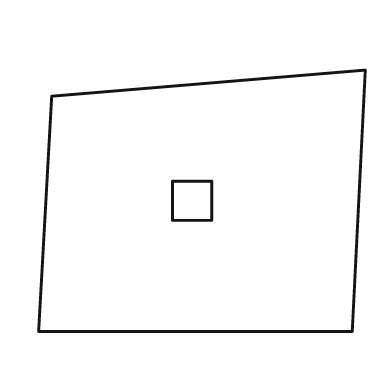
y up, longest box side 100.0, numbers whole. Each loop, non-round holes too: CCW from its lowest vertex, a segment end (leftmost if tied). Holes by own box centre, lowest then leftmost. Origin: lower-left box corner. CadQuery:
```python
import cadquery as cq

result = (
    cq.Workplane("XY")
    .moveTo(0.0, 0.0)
    .lineTo(96.0, 0.0)
    .lineTo(100.0, 80.0)
    .lineTo(4.0, 72.0)
    .close()
    .moveTo(41.0, 34.0)
    .lineTo(53.0, 34.0)
    .lineTo(53.0, 46.0)
    .lineTo(41.0, 46.0)
    .close()
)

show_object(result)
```